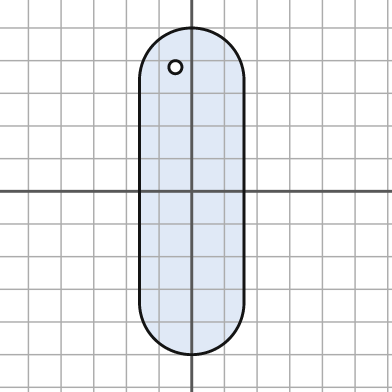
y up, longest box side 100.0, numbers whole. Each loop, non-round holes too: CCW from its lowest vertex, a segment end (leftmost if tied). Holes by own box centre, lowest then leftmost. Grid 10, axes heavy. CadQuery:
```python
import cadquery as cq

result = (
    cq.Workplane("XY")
    .moveTo(-16.0, -34.0)
    .threePointArc((0.0, -50.0), (16.0, -34.0))
    .lineTo(16.0, 34.0)
    .threePointArc((0.0, 50.0), (-16.0, 34.0))
    .close()
    .moveTo(-5.0, 38.0)
    .circle(2.0)
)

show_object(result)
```